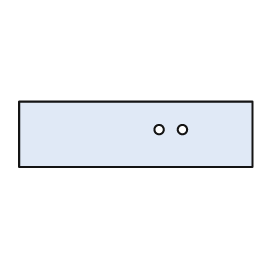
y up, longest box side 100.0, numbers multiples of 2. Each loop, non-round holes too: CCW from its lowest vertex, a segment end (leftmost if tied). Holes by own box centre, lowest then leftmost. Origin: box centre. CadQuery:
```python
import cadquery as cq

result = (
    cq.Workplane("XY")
    .moveTo(-50.0, -14.0)
    .lineTo(50.0, -14.0)
    .lineTo(50.0, 14.0)
    .lineTo(-50.0, 14.0)
    .close()
    .moveTo(10.0, 2.0)
    .circle(2.0)
    .moveTo(20.0, 2.0)
    .circle(2.0)
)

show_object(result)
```